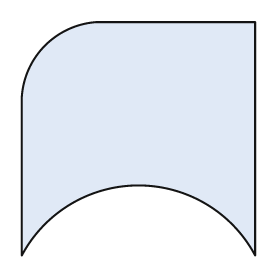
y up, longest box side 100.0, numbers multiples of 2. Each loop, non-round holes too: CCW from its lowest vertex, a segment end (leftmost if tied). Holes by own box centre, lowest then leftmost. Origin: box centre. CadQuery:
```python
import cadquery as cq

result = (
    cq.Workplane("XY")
    .moveTo(-50.0, -50.0)
    .threePointArc((0.0, -20.0), (50.0, -50.0))
    .lineTo(50.0, 50.0)
    .lineTo(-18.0, 50.0)
    .threePointArc((-40.0, 40.0), (-50.0, 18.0))
    .close()
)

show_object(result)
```